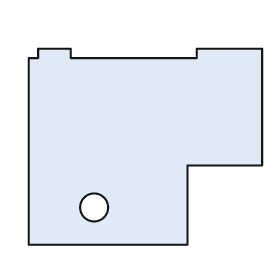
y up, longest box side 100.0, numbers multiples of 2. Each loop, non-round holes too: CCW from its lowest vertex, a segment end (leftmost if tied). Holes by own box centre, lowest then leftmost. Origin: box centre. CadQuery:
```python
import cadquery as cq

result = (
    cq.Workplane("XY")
    .moveTo(-50.0, -42.0)
    .lineTo(18.0, -42.0)
    .lineTo(18.0, -8.0)
    .lineTo(50.0, -8.0)
    .lineTo(50.0, 42.0)
    .lineTo(22.0, 42.0)
    .lineTo(22.0, 38.0)
    .lineTo(-32.0, 38.0)
    .lineTo(-32.0, 42.0)
    .lineTo(-46.0, 42.0)
    .lineTo(-46.0, 38.0)
    .lineTo(-50.0, 38.0)
    .close()
    .moveTo(-22.0, -26.0)
    .circle(6.0)
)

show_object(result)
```